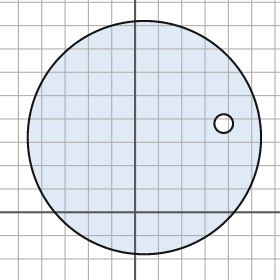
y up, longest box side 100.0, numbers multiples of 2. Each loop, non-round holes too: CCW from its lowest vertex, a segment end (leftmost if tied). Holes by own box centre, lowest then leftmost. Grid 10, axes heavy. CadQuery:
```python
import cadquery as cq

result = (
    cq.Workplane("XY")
    .moveTo(4.0, 32.0)
    .circle(50.0)
    .moveTo(38.0, 38.0)
    .circle(4.0)
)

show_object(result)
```